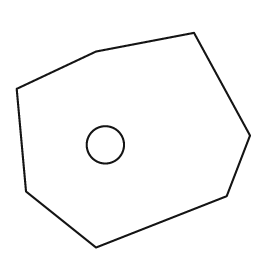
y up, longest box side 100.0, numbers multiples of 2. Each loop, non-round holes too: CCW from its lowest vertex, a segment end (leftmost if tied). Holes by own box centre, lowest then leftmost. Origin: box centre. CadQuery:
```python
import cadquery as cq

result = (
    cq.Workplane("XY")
    .moveTo(-16.0, -46.0)
    .lineTo(40.0, -24.0)
    .lineTo(50.0, 2.0)
    .lineTo(26.0, 46.0)
    .lineTo(-16.0, 38.0)
    .lineTo(-50.0, 22.0)
    .lineTo(-46.0, -22.0)
    .close()
    .moveTo(-12.0, -2.0)
    .circle(8.0)
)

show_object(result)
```